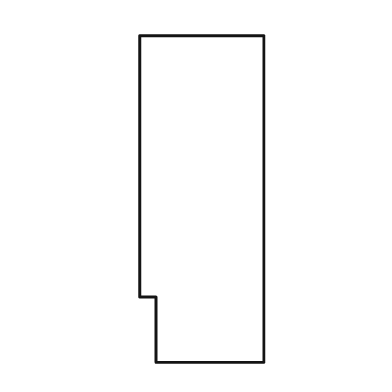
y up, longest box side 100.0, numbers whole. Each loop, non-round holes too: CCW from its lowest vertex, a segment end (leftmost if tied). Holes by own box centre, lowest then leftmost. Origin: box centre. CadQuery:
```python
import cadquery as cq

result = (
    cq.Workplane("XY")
    .moveTo(-14.0, -50.0)
    .lineTo(19.0, -50.0)
    .lineTo(19.0, 50.0)
    .lineTo(-19.0, 50.0)
    .lineTo(-19.0, -30.0)
    .lineTo(-14.0, -30.0)
    .close()
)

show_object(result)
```